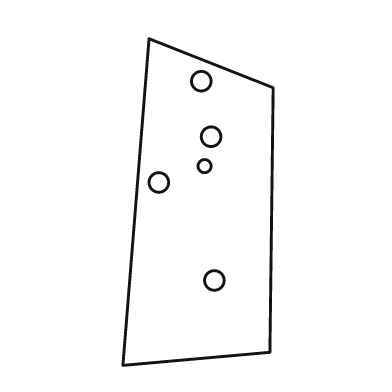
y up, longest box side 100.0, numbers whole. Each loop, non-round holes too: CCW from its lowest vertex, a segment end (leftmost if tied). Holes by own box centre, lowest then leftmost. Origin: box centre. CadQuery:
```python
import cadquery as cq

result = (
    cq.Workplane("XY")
    .moveTo(-23.0, -50.0)
    .lineTo(22.0, -46.0)
    .lineTo(23.0, 35.0)
    .lineTo(-15.0, 50.0)
    .close()
    .moveTo(5.0, -24.0)
    .circle(3.0)
    .moveTo(-12.0, 6.0)
    .circle(3.0)
    .moveTo(2.0, 11.0)
    .circle(2.0)
    .moveTo(4.0, 20.0)
    .circle(3.0)
    .moveTo(1.0, 37.0)
    .circle(3.0)
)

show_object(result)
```